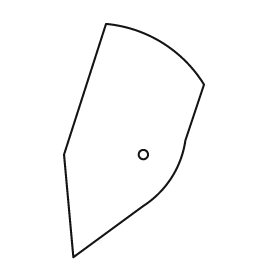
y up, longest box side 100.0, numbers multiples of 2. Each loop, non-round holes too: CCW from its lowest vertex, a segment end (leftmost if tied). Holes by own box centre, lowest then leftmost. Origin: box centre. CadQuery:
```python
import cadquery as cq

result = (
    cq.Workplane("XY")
    .moveTo(-26.0, -50.0)
    .lineTo(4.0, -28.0)
    .threePointArc((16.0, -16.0), (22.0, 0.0))
    .lineTo(30.0, 24.0)
    .threePointArc((12.0, 42.0), (-12.0, 50.0))
    .lineTo(-30.0, -6.0)
    .close()
    .moveTo(4.0, -6.0)
    .circle(2.0)
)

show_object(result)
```